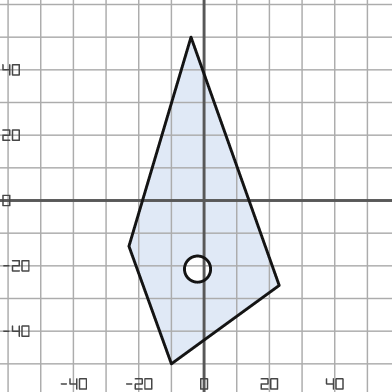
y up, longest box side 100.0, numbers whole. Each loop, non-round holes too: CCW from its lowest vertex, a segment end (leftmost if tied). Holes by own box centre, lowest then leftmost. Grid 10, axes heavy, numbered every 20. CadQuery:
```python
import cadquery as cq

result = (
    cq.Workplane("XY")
    .moveTo(-10.0, -50.0)
    .lineTo(23.0, -26.0)
    .lineTo(-4.0, 50.0)
    .lineTo(-23.0, -14.0)
    .close()
    .moveTo(-2.0, -21.0)
    .circle(4.0)
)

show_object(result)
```